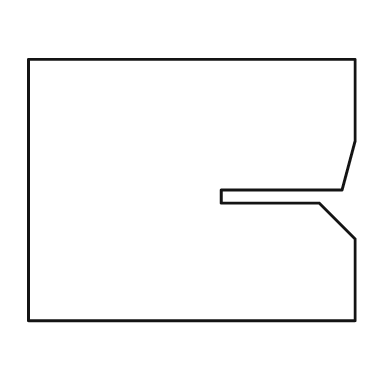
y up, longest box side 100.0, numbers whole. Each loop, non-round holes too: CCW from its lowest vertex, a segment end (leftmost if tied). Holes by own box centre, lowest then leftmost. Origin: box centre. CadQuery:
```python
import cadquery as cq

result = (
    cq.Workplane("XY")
    .moveTo(-50.0, -40.0)
    .lineTo(50.0, -40.0)
    .lineTo(50.0, -15.0)
    .lineTo(39.0, -4.0)
    .lineTo(9.0, -4.0)
    .lineTo(9.0, 0.0)
    .lineTo(46.0, 0.0)
    .lineTo(50.0, 15.0)
    .lineTo(50.0, 40.0)
    .lineTo(-50.0, 40.0)
    .close()
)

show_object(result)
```